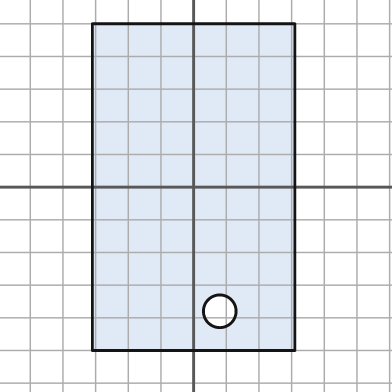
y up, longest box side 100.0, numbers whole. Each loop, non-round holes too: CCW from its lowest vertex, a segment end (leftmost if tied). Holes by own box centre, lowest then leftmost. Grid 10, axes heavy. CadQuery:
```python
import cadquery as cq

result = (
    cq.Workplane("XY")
    .moveTo(-31.0, -50.0)
    .lineTo(31.0, -50.0)
    .lineTo(31.0, 50.0)
    .lineTo(-31.0, 50.0)
    .close()
    .moveTo(8.0, -38.0)
    .circle(5.0)
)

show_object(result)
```